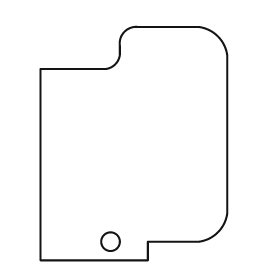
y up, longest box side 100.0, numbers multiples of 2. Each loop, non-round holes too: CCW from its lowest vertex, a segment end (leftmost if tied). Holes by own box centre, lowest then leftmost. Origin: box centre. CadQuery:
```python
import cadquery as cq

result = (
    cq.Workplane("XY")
    .moveTo(-40.0, -50.0)
    .lineTo(6.0, -50.0)
    .lineTo(6.0, -42.0)
    .lineTo(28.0, -42.0)
    .threePointArc((36.0, -38.0), (40.0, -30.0))
    .lineTo(40.0, 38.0)
    .threePointArc((36.0, 46.0), (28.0, 50.0))
    .lineTo(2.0, 50.0)
    .threePointArc((-4.0, 48.0), (-6.0, 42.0))
    .lineTo(-6.0, 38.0)
    .threePointArc((-8.0, 34.0), (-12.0, 32.0))
    .lineTo(-40.0, 32.0)
    .close()
    .moveTo(-10.0, -42.0)
    .circle(4.0)
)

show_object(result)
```